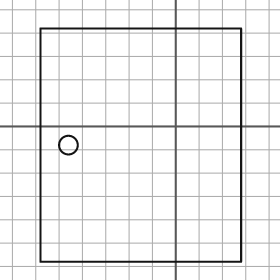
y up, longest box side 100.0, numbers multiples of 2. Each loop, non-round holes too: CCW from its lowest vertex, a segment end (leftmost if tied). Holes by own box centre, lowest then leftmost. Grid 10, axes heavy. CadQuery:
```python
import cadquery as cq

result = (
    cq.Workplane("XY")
    .moveTo(-58.0, -58.0)
    .lineTo(28.0, -58.0)
    .lineTo(28.0, 42.0)
    .lineTo(-58.0, 42.0)
    .close()
    .moveTo(-46.0, -8.0)
    .circle(4.0)
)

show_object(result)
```